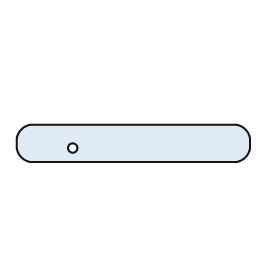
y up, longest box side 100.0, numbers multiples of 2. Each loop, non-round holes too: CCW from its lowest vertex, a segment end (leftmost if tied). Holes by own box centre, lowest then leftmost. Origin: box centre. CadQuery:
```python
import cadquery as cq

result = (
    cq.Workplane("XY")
    .moveTo(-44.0, -8.0)
    .lineTo(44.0, -8.0)
    .threePointArc((48.0, -6.0), (50.0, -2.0))
    .lineTo(50.0, 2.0)
    .threePointArc((48.0, 6.0), (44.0, 8.0))
    .lineTo(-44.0, 8.0)
    .threePointArc((-48.0, 6.0), (-50.0, 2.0))
    .lineTo(-50.0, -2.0)
    .threePointArc((-48.0, -6.0), (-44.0, -8.0))
    .close()
    .moveTo(-26.0, -2.0)
    .circle(2.0)
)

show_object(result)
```